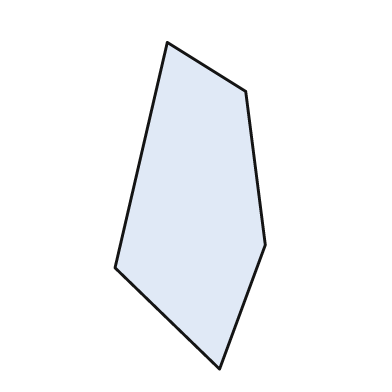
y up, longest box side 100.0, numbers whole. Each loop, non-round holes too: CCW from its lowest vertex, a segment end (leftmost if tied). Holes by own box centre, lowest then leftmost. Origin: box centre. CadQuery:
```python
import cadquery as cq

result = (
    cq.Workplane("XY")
    .moveTo(9.0, -50.0)
    .lineTo(23.0, -12.0)
    .lineTo(17.0, 35.0)
    .lineTo(-7.0, 50.0)
    .lineTo(-23.0, -19.0)
    .close()
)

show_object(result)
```